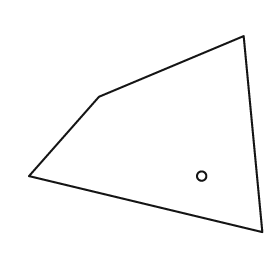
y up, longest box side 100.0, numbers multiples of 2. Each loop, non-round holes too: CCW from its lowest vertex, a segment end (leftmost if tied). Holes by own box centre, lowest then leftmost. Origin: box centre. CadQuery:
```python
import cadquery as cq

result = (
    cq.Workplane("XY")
    .moveTo(50.0, -42.0)
    .lineTo(42.0, 42.0)
    .lineTo(-20.0, 16.0)
    .lineTo(-50.0, -18.0)
    .close()
    .moveTo(24.0, -18.0)
    .circle(2.0)
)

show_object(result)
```